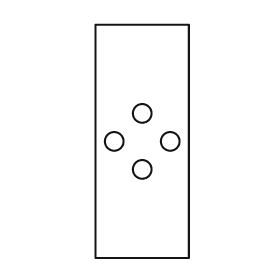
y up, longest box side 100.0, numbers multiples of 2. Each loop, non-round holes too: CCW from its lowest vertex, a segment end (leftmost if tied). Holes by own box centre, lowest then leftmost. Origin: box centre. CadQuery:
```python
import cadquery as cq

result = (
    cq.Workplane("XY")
    .moveTo(-20.0, -50.0)
    .lineTo(20.0, -50.0)
    .lineTo(20.0, 50.0)
    .lineTo(-20.0, 50.0)
    .close()
    .moveTo(0.0, -12.0)
    .circle(4.0)
    .moveTo(-12.0, 0.0)
    .circle(4.0)
    .moveTo(12.0, 0.0)
    .circle(4.0)
    .moveTo(0.0, 12.0)
    .circle(4.0)
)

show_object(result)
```